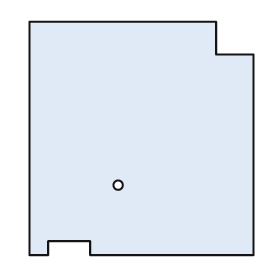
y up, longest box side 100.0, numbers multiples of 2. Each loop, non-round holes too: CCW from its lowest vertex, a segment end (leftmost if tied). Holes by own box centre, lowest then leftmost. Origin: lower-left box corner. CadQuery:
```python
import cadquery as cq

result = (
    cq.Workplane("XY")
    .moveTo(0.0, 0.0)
    .lineTo(8.0, 0.0)
    .lineTo(8.0, 6.0)
    .lineTo(26.0, 6.0)
    .lineTo(26.0, 0.0)
    .lineTo(96.0, 0.0)
    .lineTo(96.0, 86.0)
    .lineTo(80.0, 86.0)
    .lineTo(80.0, 100.0)
    .lineTo(0.0, 100.0)
    .close()
    .moveTo(38.0, 30.0)
    .circle(2.0)
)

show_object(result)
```